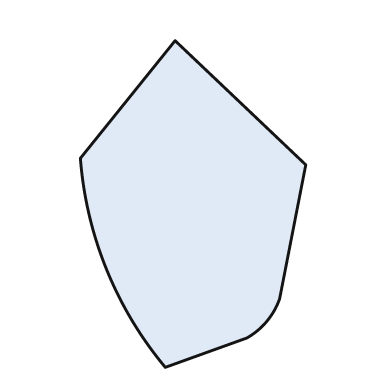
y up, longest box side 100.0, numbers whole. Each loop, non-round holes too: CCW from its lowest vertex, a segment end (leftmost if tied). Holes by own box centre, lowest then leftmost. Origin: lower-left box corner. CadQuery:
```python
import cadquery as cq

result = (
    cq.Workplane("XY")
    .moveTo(26.0, 0.0)
    .lineTo(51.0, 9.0)
    .threePointArc((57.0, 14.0), (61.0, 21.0))
    .lineTo(69.0, 62.0)
    .lineTo(29.0, 100.0)
    .lineTo(0.0, 64.0)
    .threePointArc((8.0, 30.0), (26.0, 0.0))
    .close()
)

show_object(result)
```